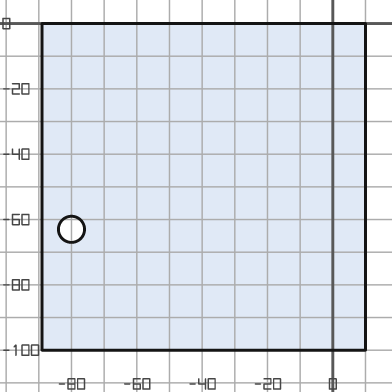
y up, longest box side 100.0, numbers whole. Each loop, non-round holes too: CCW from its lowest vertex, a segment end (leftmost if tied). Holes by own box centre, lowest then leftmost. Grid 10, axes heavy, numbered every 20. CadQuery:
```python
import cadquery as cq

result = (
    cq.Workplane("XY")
    .moveTo(-89.0, -100.0)
    .lineTo(10.0, -100.0)
    .lineTo(10.0, 0.0)
    .lineTo(-89.0, 0.0)
    .close()
    .moveTo(-80.0, -63.0)
    .circle(4.0)
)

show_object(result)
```